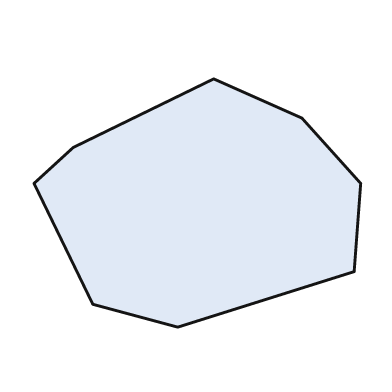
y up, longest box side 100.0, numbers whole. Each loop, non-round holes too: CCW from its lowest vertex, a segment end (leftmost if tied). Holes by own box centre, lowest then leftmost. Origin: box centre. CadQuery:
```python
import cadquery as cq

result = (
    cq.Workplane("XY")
    .moveTo(-6.0, -38.0)
    .lineTo(48.0, -21.0)
    .lineTo(50.0, 6.0)
    .lineTo(32.0, 26.0)
    .lineTo(5.0, 38.0)
    .lineTo(-38.0, 17.0)
    .lineTo(-50.0, 6.0)
    .lineTo(-32.0, -31.0)
    .close()
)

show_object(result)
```